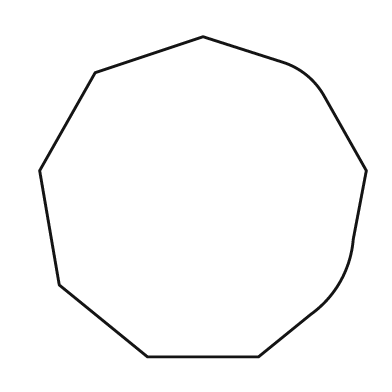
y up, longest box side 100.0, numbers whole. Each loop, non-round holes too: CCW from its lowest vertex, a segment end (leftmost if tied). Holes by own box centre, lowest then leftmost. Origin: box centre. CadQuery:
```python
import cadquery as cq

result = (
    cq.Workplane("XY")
    .moveTo(-17.0, -49.0)
    .lineTo(17.0, -49.0)
    .lineTo(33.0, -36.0)
    .threePointArc((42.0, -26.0), (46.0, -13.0))
    .lineTo(50.0, 8.0)
    .lineTo(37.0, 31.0)
    .threePointArc((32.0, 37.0), (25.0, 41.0))
    .lineTo(0.0, 49.0)
    .lineTo(-33.0, 38.0)
    .lineTo(-50.0, 8.0)
    .lineTo(-44.0, -27.0)
    .close()
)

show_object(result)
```